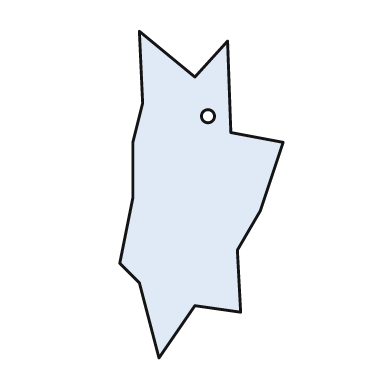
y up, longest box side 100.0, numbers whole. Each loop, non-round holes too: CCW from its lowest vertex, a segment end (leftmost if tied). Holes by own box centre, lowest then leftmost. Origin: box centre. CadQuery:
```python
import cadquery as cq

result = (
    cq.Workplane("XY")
    .moveTo(-13.0, -50.0)
    .lineTo(-2.0, -34.0)
    .lineTo(12.0, -36.0)
    .lineTo(11.0, -17.0)
    .lineTo(18.0, -5.0)
    .lineTo(25.0, 16.0)
    .lineTo(9.0, 19.0)
    .lineTo(8.0, 47.0)
    .lineTo(-2.0, 36.0)
    .lineTo(-19.0, 50.0)
    .lineTo(-18.0, 28.0)
    .lineTo(-21.0, 16.0)
    .lineTo(-21.0, -1.0)
    .lineTo(-25.0, -21.0)
    .lineTo(-19.0, -27.0)
    .close()
    .moveTo(2.0, 24.0)
    .circle(2.0)
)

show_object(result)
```